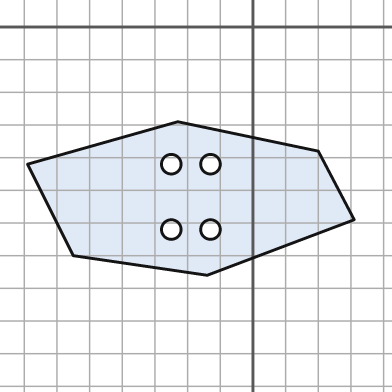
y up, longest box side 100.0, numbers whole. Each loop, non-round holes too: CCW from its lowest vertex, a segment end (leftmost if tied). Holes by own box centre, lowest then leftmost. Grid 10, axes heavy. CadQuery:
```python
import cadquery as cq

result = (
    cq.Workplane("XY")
    .moveTo(-14.0, -76.0)
    .lineTo(31.0, -59.0)
    .lineTo(20.0, -38.0)
    .lineTo(-23.0, -29.0)
    .lineTo(-69.0, -42.0)
    .lineTo(-55.0, -70.0)
    .close()
    .moveTo(-25.0, -62.0)
    .circle(3.0)
    .moveTo(-13.0, -62.0)
    .circle(3.0)
    .moveTo(-25.0, -42.0)
    .circle(3.0)
    .moveTo(-13.0, -42.0)
    .circle(3.0)
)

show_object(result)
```